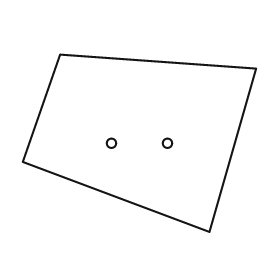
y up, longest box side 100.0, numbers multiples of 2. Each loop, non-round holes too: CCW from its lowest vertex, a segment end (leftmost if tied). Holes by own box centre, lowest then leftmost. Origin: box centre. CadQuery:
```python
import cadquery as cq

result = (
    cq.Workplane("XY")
    .moveTo(30.0, -38.0)
    .lineTo(50.0, 32.0)
    .lineTo(-34.0, 38.0)
    .lineTo(-50.0, -8.0)
    .close()
    .moveTo(-12.0, 0.0)
    .circle(2.0)
    .moveTo(12.0, 0.0)
    .circle(2.0)
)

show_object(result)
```